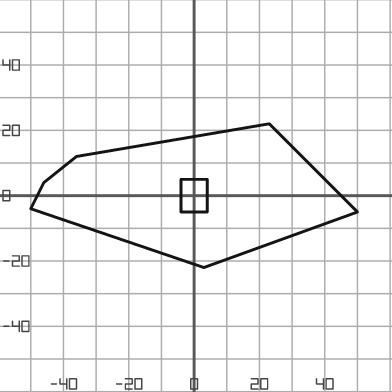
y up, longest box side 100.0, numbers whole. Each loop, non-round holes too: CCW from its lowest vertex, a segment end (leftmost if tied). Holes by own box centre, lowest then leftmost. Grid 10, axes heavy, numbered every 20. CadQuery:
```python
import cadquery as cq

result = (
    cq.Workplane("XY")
    .moveTo(3.0, -22.0)
    .lineTo(50.0, -5.0)
    .lineTo(23.0, 22.0)
    .lineTo(-36.0, 12.0)
    .lineTo(-46.0, 4.0)
    .lineTo(-50.0, -4.0)
    .close()
    .moveTo(-4.0, -5.0)
    .lineTo(4.0, -5.0)
    .lineTo(4.0, 5.0)
    .lineTo(-4.0, 5.0)
    .close()
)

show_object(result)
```